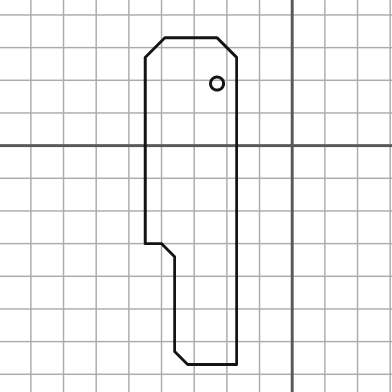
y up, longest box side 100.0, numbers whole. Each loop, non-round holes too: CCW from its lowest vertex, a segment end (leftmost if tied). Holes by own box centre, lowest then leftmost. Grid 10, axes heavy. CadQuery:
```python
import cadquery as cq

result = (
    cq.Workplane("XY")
    .moveTo(-32.0, -67.0)
    .lineTo(-17.0, -67.0)
    .lineTo(-17.0, 27.0)
    .lineTo(-23.0, 33.0)
    .lineTo(-39.0, 33.0)
    .lineTo(-45.0, 27.0)
    .lineTo(-45.0, -30.0)
    .lineTo(-40.0, -30.0)
    .lineTo(-36.0, -34.0)
    .lineTo(-36.0, -63.0)
    .close()
    .moveTo(-23.0, 19.0)
    .circle(2.0)
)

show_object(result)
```